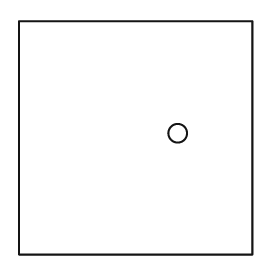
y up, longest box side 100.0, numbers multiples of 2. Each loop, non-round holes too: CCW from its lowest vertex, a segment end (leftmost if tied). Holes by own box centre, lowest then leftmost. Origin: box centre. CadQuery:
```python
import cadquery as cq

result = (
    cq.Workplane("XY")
    .moveTo(-50.0, -50.0)
    .lineTo(50.0, -50.0)
    .lineTo(50.0, 50.0)
    .lineTo(-50.0, 50.0)
    .close()
    .moveTo(18.0, 2.0)
    .circle(4.0)
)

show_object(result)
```